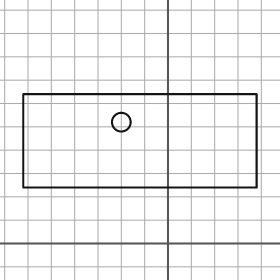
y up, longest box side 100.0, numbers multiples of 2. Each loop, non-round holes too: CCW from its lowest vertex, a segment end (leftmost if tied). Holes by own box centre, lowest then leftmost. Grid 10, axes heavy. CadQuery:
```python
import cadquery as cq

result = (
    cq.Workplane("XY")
    .moveTo(-62.0, 24.0)
    .lineTo(38.0, 24.0)
    .lineTo(38.0, 64.0)
    .lineTo(-62.0, 64.0)
    .close()
    .moveTo(-20.0, 52.0)
    .circle(4.0)
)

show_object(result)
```